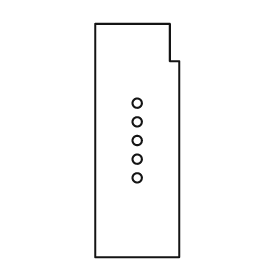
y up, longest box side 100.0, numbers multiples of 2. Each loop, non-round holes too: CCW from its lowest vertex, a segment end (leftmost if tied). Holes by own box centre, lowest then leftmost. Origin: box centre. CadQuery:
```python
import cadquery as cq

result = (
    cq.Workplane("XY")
    .moveTo(-18.0, -50.0)
    .lineTo(18.0, -50.0)
    .lineTo(18.0, 34.0)
    .lineTo(14.0, 34.0)
    .lineTo(14.0, 50.0)
    .lineTo(-18.0, 50.0)
    .close()
    .moveTo(0.0, -16.0)
    .circle(2.0)
    .moveTo(0.0, -8.0)
    .circle(2.0)
    .moveTo(0.0, 0.0)
    .circle(2.0)
    .moveTo(0.0, 8.0)
    .circle(2.0)
    .moveTo(0.0, 16.0)
    .circle(2.0)
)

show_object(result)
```